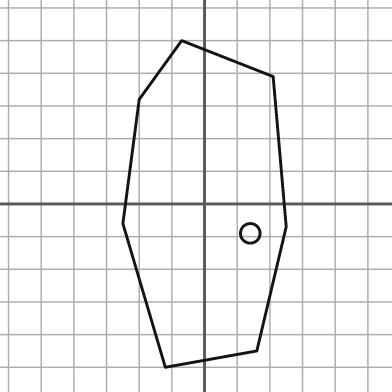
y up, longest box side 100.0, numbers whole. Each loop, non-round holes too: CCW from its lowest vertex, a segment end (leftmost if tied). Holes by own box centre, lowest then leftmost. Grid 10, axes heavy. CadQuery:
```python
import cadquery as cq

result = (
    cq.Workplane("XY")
    .moveTo(-12.0, -50.0)
    .lineTo(16.0, -45.0)
    .lineTo(25.0, -7.0)
    .lineTo(21.0, 39.0)
    .lineTo(-7.0, 50.0)
    .lineTo(-20.0, 32.0)
    .lineTo(-25.0, -6.0)
    .close()
    .moveTo(14.0, -9.0)
    .circle(3.0)
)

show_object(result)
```